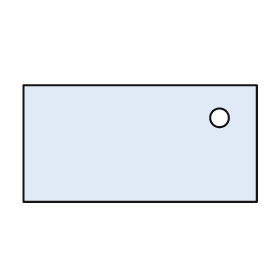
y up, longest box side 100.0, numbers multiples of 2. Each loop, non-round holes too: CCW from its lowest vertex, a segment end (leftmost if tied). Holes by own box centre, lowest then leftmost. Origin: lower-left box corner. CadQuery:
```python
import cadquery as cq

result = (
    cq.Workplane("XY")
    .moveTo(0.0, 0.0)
    .lineTo(100.0, 0.0)
    .lineTo(100.0, 50.0)
    .lineTo(0.0, 50.0)
    .close()
    .moveTo(84.0, 36.0)
    .circle(4.0)
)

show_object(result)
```